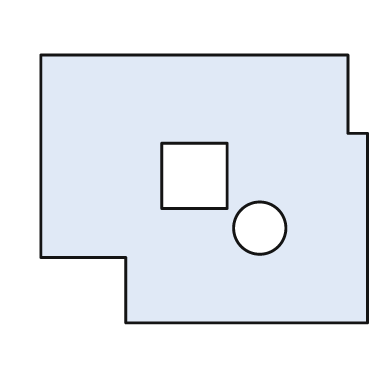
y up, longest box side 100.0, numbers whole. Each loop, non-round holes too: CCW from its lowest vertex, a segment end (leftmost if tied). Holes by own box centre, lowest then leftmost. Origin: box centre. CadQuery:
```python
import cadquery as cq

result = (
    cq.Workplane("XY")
    .moveTo(-24.0, -41.0)
    .lineTo(50.0, -41.0)
    .lineTo(50.0, 17.0)
    .lineTo(44.0, 17.0)
    .lineTo(44.0, 41.0)
    .lineTo(-50.0, 41.0)
    .lineTo(-50.0, -21.0)
    .lineTo(-24.0, -21.0)
    .close()
    .moveTo(17.0, -12.0)
    .circle(8.0)
    .moveTo(-13.0, -6.0)
    .lineTo(7.0, -6.0)
    .lineTo(7.0, 14.0)
    .lineTo(-13.0, 14.0)
    .close()
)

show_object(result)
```